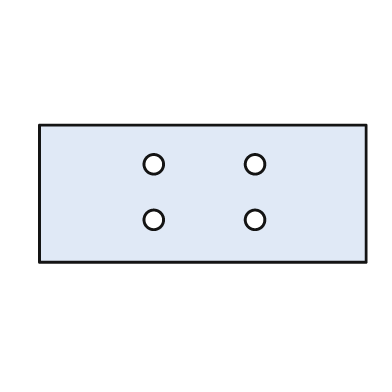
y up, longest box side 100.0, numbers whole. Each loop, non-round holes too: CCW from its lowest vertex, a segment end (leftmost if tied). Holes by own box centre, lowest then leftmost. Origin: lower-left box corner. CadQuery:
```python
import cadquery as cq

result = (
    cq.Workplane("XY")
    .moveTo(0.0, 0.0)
    .lineTo(100.0, 0.0)
    .lineTo(100.0, 42.0)
    .lineTo(0.0, 42.0)
    .close()
    .moveTo(35.0, 13.0)
    .circle(3.0)
    .moveTo(66.0, 13.0)
    .circle(3.0)
    .moveTo(35.0, 30.0)
    .circle(3.0)
    .moveTo(66.0, 30.0)
    .circle(3.0)
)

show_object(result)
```